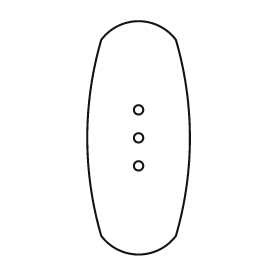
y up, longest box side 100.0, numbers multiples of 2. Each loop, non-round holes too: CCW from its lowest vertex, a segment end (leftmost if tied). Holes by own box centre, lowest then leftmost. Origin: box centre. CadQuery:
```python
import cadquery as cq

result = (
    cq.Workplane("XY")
    .moveTo(-16.0, -42.0)
    .threePointArc((0.0, -50.0), (16.0, -42.0))
    .threePointArc((22.0, 0.0), (16.0, 42.0))
    .threePointArc((0.0, 50.0), (-16.0, 42.0))
    .threePointArc((-22.0, 0.0), (-16.0, -42.0))
    .close()
    .moveTo(0.0, -12.0)
    .circle(2.0)
    .moveTo(0.0, 0.0)
    .circle(2.0)
    .moveTo(0.0, 12.0)
    .circle(2.0)
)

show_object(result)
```